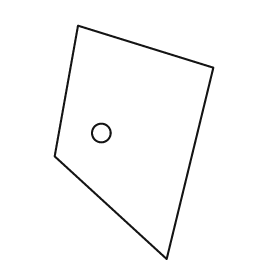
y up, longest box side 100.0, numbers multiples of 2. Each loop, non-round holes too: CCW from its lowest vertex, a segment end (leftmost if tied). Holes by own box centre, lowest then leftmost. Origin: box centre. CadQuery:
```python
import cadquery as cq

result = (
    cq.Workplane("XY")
    .moveTo(14.0, -50.0)
    .lineTo(34.0, 32.0)
    .lineTo(-24.0, 50.0)
    .lineTo(-34.0, -6.0)
    .close()
    .moveTo(-14.0, 4.0)
    .circle(4.0)
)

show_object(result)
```